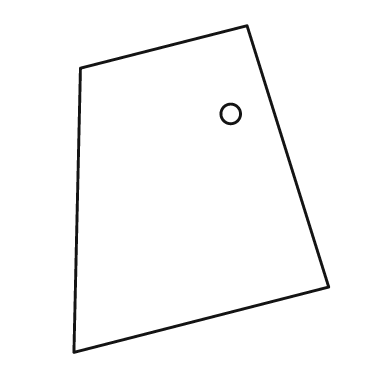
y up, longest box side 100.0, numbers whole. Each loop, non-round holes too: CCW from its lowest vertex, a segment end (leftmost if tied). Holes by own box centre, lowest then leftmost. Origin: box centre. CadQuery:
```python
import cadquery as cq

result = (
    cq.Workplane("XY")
    .moveTo(-39.0, -50.0)
    .lineTo(39.0, -30.0)
    .lineTo(14.0, 50.0)
    .lineTo(-37.0, 37.0)
    .close()
    .moveTo(9.0, 23.0)
    .circle(3.0)
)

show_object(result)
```